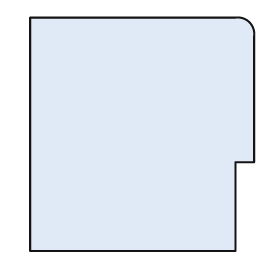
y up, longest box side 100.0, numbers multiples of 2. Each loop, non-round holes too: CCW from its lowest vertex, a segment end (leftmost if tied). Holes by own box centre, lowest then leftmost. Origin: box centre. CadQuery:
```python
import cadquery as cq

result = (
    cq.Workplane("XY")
    .moveTo(-48.0, -50.0)
    .lineTo(40.0, -50.0)
    .lineTo(40.0, -12.0)
    .lineTo(48.0, -12.0)
    .lineTo(48.0, 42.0)
    .threePointArc((46.0, 48.0), (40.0, 50.0))
    .lineTo(-48.0, 50.0)
    .close()
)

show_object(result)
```